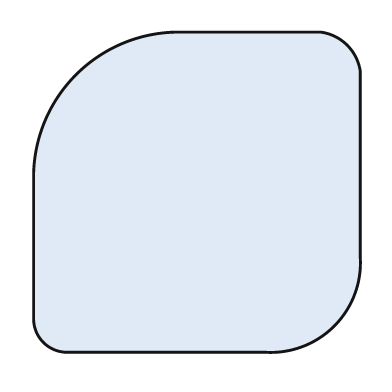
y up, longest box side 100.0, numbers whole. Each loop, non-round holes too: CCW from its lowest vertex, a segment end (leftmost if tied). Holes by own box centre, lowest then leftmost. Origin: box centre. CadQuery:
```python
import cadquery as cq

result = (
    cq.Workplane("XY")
    .moveTo(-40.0, -49.0)
    .lineTo(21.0, -49.0)
    .threePointArc((42.0, -41.0), (50.0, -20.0))
    .lineTo(50.0, 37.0)
    .threePointArc((46.0, 45.0), (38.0, 49.0))
    .lineTo(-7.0, 49.0)
    .threePointArc((-37.0, 36.0), (-50.0, 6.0))
    .lineTo(-50.0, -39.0)
    .threePointArc((-47.0, -46.0), (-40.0, -49.0))
    .close()
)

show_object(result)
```